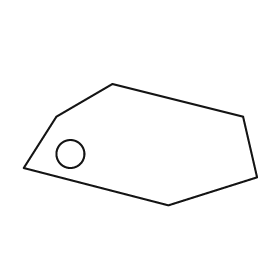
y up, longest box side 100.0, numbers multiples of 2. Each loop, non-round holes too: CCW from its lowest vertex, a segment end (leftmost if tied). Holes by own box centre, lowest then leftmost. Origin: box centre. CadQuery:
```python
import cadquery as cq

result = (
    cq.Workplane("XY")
    .moveTo(12.0, -26.0)
    .lineTo(50.0, -14.0)
    .lineTo(44.0, 12.0)
    .lineTo(-12.0, 26.0)
    .lineTo(-36.0, 12.0)
    .lineTo(-50.0, -10.0)
    .close()
    .moveTo(-30.0, -4.0)
    .circle(6.0)
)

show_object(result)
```